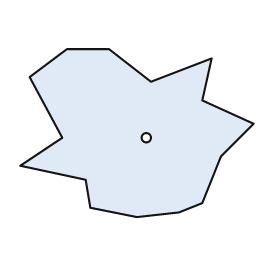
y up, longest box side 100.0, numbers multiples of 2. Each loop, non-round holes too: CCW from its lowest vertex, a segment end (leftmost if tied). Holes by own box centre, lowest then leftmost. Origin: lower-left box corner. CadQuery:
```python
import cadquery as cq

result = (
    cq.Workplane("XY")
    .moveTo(50.0, 0.0)
    .lineTo(68.0, 2.0)
    .lineTo(78.0, 6.0)
    .lineTo(86.0, 26.0)
    .lineTo(100.0, 40.0)
    .lineTo(78.0, 50.0)
    .lineTo(82.0, 68.0)
    .lineTo(56.0, 58.0)
    .lineTo(38.0, 72.0)
    .lineTo(20.0, 72.0)
    .lineTo(4.0, 60.0)
    .lineTo(18.0, 34.0)
    .lineTo(0.0, 22.0)
    .lineTo(28.0, 16.0)
    .lineTo(30.0, 4.0)
    .close()
    .moveTo(54.0, 34.0)
    .circle(2.0)
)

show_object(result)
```